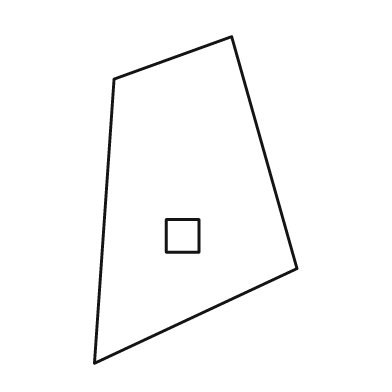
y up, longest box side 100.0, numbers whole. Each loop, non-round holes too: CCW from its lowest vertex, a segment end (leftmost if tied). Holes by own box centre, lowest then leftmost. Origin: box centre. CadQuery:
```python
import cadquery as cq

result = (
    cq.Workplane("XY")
    .moveTo(-31.0, -50.0)
    .lineTo(31.0, -21.0)
    .lineTo(11.0, 50.0)
    .lineTo(-25.0, 37.0)
    .close()
    .moveTo(-9.0, -16.0)
    .lineTo(1.0, -16.0)
    .lineTo(1.0, -6.0)
    .lineTo(-9.0, -6.0)
    .close()
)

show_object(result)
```